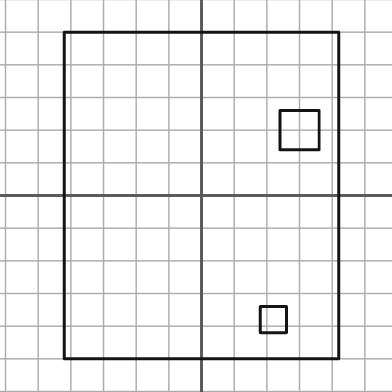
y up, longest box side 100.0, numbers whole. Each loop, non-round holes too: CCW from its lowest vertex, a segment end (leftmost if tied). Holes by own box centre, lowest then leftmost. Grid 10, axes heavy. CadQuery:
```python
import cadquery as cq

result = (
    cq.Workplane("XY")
    .moveTo(-42.0, -50.0)
    .lineTo(42.0, -50.0)
    .lineTo(42.0, 50.0)
    .lineTo(-42.0, 50.0)
    .close()
    .moveTo(18.0, -42.0)
    .lineTo(26.0, -42.0)
    .lineTo(26.0, -34.0)
    .lineTo(18.0, -34.0)
    .close()
    .moveTo(24.0, 14.0)
    .lineTo(36.0, 14.0)
    .lineTo(36.0, 26.0)
    .lineTo(24.0, 26.0)
    .close()
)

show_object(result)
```